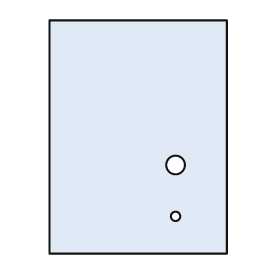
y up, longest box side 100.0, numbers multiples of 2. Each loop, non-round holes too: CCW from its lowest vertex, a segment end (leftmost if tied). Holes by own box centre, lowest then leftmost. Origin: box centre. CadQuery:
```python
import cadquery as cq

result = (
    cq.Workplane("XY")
    .moveTo(-38.0, -50.0)
    .lineTo(38.0, -50.0)
    .lineTo(38.0, 50.0)
    .lineTo(-38.0, 50.0)
    .close()
    .moveTo(16.0, -34.0)
    .circle(2.0)
    .moveTo(16.0, -12.0)
    .circle(4.0)
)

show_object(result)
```